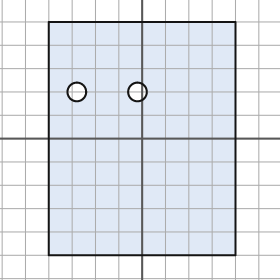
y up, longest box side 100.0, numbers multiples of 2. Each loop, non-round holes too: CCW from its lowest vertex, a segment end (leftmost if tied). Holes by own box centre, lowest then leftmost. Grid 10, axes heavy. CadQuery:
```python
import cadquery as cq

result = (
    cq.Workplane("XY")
    .moveTo(-40.0, -50.0)
    .lineTo(40.0, -50.0)
    .lineTo(40.0, 50.0)
    .lineTo(-40.0, 50.0)
    .close()
    .moveTo(-28.0, 20.0)
    .circle(4.0)
    .moveTo(-2.0, 20.0)
    .circle(4.0)
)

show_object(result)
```